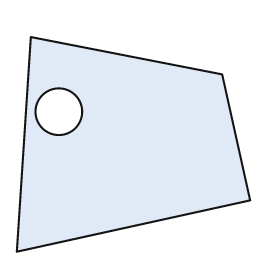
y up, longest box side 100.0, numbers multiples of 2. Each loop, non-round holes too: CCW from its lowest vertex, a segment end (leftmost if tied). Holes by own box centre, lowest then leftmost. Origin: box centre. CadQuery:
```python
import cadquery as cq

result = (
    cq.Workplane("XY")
    .moveTo(-50.0, -46.0)
    .lineTo(50.0, -24.0)
    .lineTo(38.0, 30.0)
    .lineTo(-44.0, 46.0)
    .close()
    .moveTo(-32.0, 14.0)
    .circle(10.0)
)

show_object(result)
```